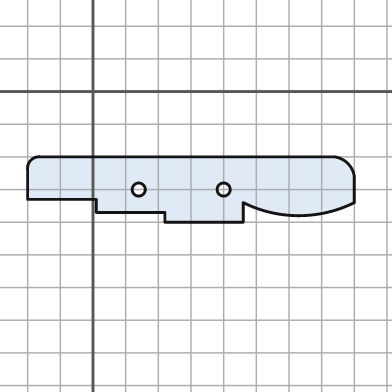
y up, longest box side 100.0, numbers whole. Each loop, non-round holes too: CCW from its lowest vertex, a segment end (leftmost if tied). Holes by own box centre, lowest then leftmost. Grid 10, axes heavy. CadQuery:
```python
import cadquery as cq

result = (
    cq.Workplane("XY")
    .moveTo(22.0, -40.0)
    .lineTo(46.0, -40.0)
    .lineTo(46.0, -34.0)
    .threePointArc((63.0, -38.0), (80.0, -34.0))
    .lineTo(80.0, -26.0)
    .threePointArc((78.0, -22.0), (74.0, -20.0))
    .lineTo(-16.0, -20.0)
    .threePointArc((-19.0, -21.0), (-20.0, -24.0))
    .lineTo(-20.0, -33.0)
    .lineTo(1.0, -33.0)
    .lineTo(1.0, -37.0)
    .lineTo(22.0, -37.0)
    .close()
    .moveTo(14.0, -30.0)
    .circle(2.0)
    .moveTo(40.0, -30.0)
    .circle(2.0)
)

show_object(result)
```